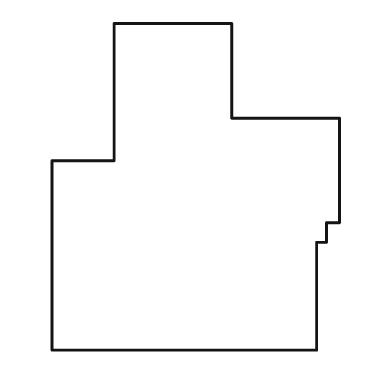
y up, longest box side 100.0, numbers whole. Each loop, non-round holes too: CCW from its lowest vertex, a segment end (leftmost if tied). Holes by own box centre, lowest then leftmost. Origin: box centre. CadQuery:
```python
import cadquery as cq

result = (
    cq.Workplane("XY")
    .moveTo(-44.0, -50.0)
    .lineTo(37.0, -50.0)
    .lineTo(37.0, -17.0)
    .lineTo(40.0, -17.0)
    .lineTo(40.0, -11.0)
    .lineTo(44.0, -11.0)
    .lineTo(44.0, 21.0)
    .lineTo(11.0, 21.0)
    .lineTo(11.0, 50.0)
    .lineTo(-25.0, 50.0)
    .lineTo(-25.0, 8.0)
    .lineTo(-44.0, 8.0)
    .close()
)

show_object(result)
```